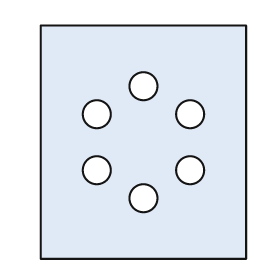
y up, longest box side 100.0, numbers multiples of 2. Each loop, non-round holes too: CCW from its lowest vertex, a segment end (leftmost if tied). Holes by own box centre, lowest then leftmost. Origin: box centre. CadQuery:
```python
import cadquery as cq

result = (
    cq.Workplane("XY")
    .moveTo(-44.0, -50.0)
    .lineTo(44.0, -50.0)
    .lineTo(44.0, 50.0)
    .lineTo(-44.0, 50.0)
    .close()
    .moveTo(0.0, -24.0)
    .circle(6.0)
    .moveTo(-20.0, -12.0)
    .circle(6.0)
    .moveTo(20.0, -12.0)
    .circle(6.0)
    .moveTo(-20.0, 12.0)
    .circle(6.0)
    .moveTo(20.0, 12.0)
    .circle(6.0)
    .moveTo(0.0, 24.0)
    .circle(6.0)
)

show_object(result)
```